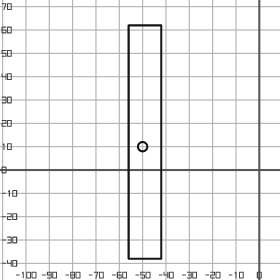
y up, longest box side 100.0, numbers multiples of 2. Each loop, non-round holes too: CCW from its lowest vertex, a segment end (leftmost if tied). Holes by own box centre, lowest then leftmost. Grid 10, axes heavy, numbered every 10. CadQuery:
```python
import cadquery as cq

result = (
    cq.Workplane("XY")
    .moveTo(-56.0, -38.0)
    .lineTo(-42.0, -38.0)
    .lineTo(-42.0, 62.0)
    .lineTo(-56.0, 62.0)
    .close()
    .moveTo(-50.0, 10.0)
    .circle(2.0)
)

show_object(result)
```